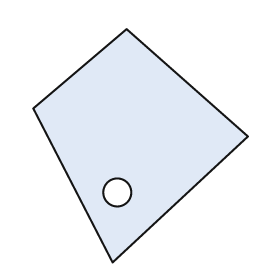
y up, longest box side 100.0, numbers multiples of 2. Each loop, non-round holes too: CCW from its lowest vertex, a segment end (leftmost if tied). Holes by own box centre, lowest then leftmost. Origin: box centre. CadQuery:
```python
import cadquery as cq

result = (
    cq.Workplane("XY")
    .moveTo(-12.0, -50.0)
    .lineTo(46.0, 4.0)
    .lineTo(-6.0, 50.0)
    .lineTo(-46.0, 16.0)
    .close()
    .moveTo(-10.0, -20.0)
    .circle(6.0)
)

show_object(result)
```